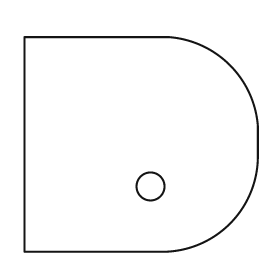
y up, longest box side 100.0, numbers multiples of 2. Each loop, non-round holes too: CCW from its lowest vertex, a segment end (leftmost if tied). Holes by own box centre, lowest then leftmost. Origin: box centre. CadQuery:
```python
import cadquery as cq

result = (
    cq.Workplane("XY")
    .moveTo(-50.0, -46.0)
    .lineTo(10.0, -46.0)
    .threePointArc((38.0, -34.0), (50.0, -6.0))
    .lineTo(50.0, 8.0)
    .threePointArc((38.0, 34.0), (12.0, 46.0))
    .lineTo(-50.0, 46.0)
    .close()
    .moveTo(4.0, -18.0)
    .circle(6.0)
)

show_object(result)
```